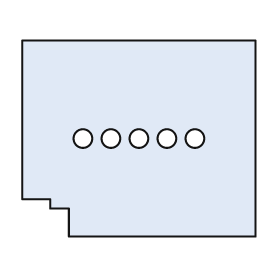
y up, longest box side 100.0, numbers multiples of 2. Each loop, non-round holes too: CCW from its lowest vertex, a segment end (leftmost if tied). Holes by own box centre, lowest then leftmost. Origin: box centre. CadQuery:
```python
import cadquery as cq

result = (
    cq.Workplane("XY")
    .moveTo(-30.0, -42.0)
    .lineTo(50.0, -42.0)
    .lineTo(50.0, 42.0)
    .lineTo(-50.0, 42.0)
    .lineTo(-50.0, -26.0)
    .lineTo(-38.0, -26.0)
    .lineTo(-38.0, -30.0)
    .lineTo(-30.0, -30.0)
    .close()
    .moveTo(-24.0, 0.0)
    .circle(4.0)
    .moveTo(-12.0, 0.0)
    .circle(4.0)
    .moveTo(0.0, 0.0)
    .circle(4.0)
    .moveTo(12.0, 0.0)
    .circle(4.0)
    .moveTo(24.0, 0.0)
    .circle(4.0)
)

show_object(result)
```